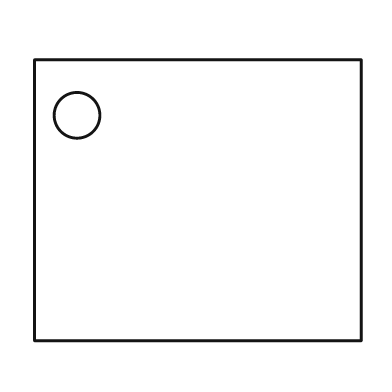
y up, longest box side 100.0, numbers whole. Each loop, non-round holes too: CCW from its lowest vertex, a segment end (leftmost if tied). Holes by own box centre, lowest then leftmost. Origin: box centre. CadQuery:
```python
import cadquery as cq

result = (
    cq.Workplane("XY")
    .moveTo(-50.0, -43.0)
    .lineTo(50.0, -43.0)
    .lineTo(50.0, 43.0)
    .lineTo(-50.0, 43.0)
    .close()
    .moveTo(-37.0, 26.0)
    .circle(7.0)
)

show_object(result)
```